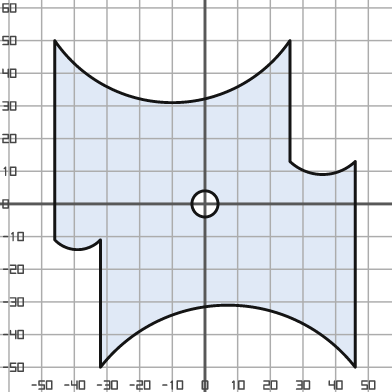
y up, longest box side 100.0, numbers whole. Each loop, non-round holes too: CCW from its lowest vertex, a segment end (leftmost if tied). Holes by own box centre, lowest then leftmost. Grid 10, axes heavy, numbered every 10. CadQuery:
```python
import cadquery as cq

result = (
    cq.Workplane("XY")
    .moveTo(-32.0, -50.0)
    .threePointArc((7.0, -31.0), (46.0, -50.0))
    .lineTo(46.0, 13.0)
    .threePointArc((36.0, 9.0), (26.0, 13.0))
    .lineTo(26.0, 50.0)
    .threePointArc((-10.0, 31.0), (-46.0, 50.0))
    .lineTo(-46.0, -11.0)
    .threePointArc((-39.0, -14.0), (-32.0, -11.0))
    .close()
    .moveTo(0.0, 0.0)
    .circle(4.0)
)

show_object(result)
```